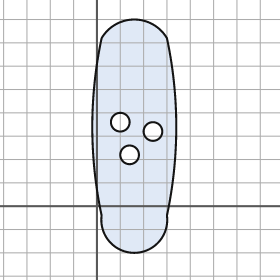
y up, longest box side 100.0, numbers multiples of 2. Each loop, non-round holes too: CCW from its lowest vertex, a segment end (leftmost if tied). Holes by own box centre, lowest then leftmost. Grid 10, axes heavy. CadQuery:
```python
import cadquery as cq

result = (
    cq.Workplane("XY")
    .moveTo(2.0, -4.0)
    .threePointArc((16.0, -20.0), (30.0, -4.0))
    .threePointArc((34.0, 34.0), (30.0, 72.0))
    .threePointArc((16.0, 80.0), (2.0, 72.0))
    .threePointArc((-2.0, 34.0), (2.0, -4.0))
    .close()
    .moveTo(14.0, 22.0)
    .circle(4.0)
    .moveTo(24.0, 32.0)
    .circle(4.0)
    .moveTo(10.0, 36.0)
    .circle(4.0)
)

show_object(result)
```